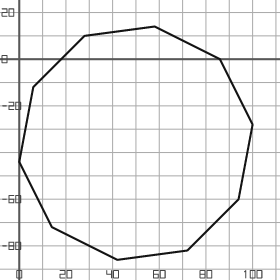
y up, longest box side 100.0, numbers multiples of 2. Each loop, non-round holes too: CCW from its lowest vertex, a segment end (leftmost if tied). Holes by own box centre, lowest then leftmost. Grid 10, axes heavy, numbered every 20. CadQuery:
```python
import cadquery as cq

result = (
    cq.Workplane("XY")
    .moveTo(42.0, -86.0)
    .lineTo(72.0, -82.0)
    .lineTo(94.0, -60.0)
    .lineTo(100.0, -28.0)
    .lineTo(86.0, 0.0)
    .lineTo(58.0, 14.0)
    .lineTo(28.0, 10.0)
    .lineTo(6.0, -12.0)
    .lineTo(0.0, -44.0)
    .lineTo(14.0, -72.0)
    .close()
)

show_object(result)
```